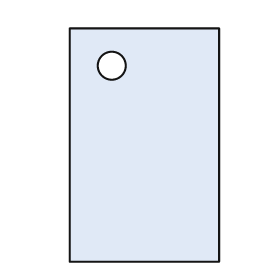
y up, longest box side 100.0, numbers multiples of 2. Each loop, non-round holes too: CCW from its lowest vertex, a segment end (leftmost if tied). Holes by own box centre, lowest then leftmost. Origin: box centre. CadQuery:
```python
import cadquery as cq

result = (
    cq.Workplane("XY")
    .moveTo(-32.0, -50.0)
    .lineTo(32.0, -50.0)
    .lineTo(32.0, 50.0)
    .lineTo(-32.0, 50.0)
    .close()
    .moveTo(-14.0, 34.0)
    .circle(6.0)
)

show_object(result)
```